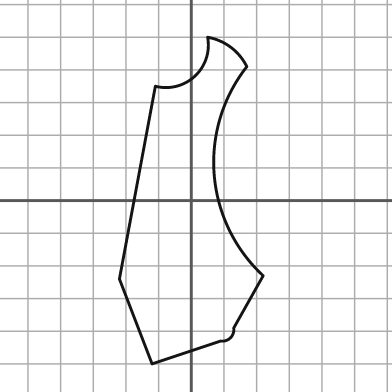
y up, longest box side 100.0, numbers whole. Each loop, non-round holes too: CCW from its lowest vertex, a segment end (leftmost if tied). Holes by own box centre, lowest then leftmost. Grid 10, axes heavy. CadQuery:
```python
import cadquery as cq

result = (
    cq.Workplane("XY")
    .moveTo(-12.0, -50.0)
    .lineTo(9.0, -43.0)
    .threePointArc((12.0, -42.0), (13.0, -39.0))
    .lineTo(22.0, -23.0)
    .threePointArc((7.0, 8.0), (17.0, 41.0))
    .threePointArc((12.0, 47.0), (5.0, 50.0))
    .threePointArc((1.0, 38.0), (-11.0, 35.0))
    .lineTo(-22.0, -24.0)
    .close()
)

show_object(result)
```